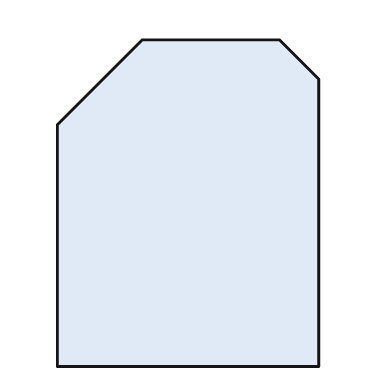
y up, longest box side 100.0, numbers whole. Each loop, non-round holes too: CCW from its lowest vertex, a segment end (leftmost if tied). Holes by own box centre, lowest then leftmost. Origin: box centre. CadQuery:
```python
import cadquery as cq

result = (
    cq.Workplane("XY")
    .moveTo(-40.0, -50.0)
    .lineTo(40.0, -50.0)
    .lineTo(40.0, 38.0)
    .lineTo(28.0, 50.0)
    .lineTo(-14.0, 50.0)
    .lineTo(-40.0, 24.0)
    .close()
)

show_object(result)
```